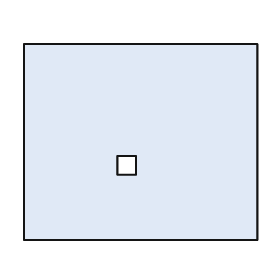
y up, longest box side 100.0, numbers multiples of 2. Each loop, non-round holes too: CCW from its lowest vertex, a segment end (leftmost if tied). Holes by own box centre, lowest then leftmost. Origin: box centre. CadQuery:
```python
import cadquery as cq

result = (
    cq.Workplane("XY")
    .moveTo(-50.0, -42.0)
    .lineTo(50.0, -42.0)
    .lineTo(50.0, 42.0)
    .lineTo(-50.0, 42.0)
    .close()
    .moveTo(-10.0, -14.0)
    .lineTo(-2.0, -14.0)
    .lineTo(-2.0, -6.0)
    .lineTo(-10.0, -6.0)
    .close()
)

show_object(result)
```